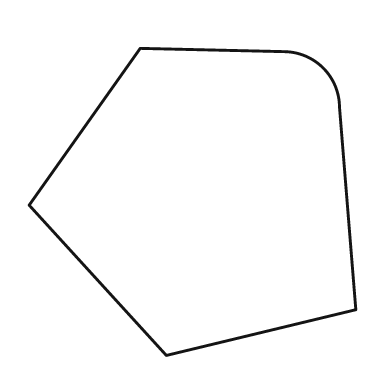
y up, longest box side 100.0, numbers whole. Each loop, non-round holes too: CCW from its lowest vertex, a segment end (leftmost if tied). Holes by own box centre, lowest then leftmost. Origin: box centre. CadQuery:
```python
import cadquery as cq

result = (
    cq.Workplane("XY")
    .moveTo(-8.0, -47.0)
    .lineTo(50.0, -33.0)
    .lineTo(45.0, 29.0)
    .threePointArc((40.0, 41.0), (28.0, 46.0))
    .lineTo(-16.0, 47.0)
    .lineTo(-50.0, -1.0)
    .close()
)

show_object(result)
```